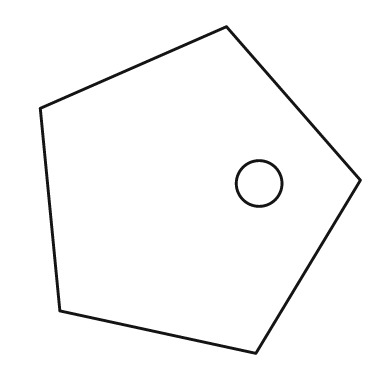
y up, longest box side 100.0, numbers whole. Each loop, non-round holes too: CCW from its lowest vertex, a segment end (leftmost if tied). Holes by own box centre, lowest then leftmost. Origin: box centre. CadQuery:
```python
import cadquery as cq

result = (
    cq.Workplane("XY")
    .moveTo(17.0, -50.0)
    .lineTo(49.0, 3.0)
    .lineTo(8.0, 50.0)
    .lineTo(-49.0, 25.0)
    .lineTo(-43.0, -37.0)
    .close()
    .moveTo(18.0, 2.0)
    .circle(7.0)
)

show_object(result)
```